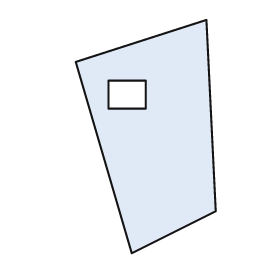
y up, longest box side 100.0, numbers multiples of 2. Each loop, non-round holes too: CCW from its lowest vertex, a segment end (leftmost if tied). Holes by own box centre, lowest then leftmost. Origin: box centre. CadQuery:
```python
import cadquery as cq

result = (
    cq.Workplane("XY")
    .moveTo(-6.0, -50.0)
    .lineTo(30.0, -32.0)
    .lineTo(26.0, 50.0)
    .lineTo(-30.0, 32.0)
    .close()
    .moveTo(-16.0, 12.0)
    .lineTo(0.0, 12.0)
    .lineTo(0.0, 24.0)
    .lineTo(-16.0, 24.0)
    .close()
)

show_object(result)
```